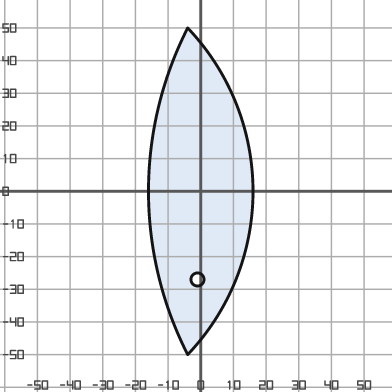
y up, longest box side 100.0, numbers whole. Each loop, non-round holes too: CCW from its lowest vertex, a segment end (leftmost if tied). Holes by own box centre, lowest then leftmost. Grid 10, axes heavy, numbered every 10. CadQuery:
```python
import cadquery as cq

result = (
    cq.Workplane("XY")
    .moveTo(-4.0, -50.0)
    .threePointArc((16.0, 0.0), (-4.0, 50.0))
    .threePointArc((-16.0, 0.0), (-4.0, -50.0))
    .close()
    .moveTo(-1.0, -27.0)
    .circle(2.0)
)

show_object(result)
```